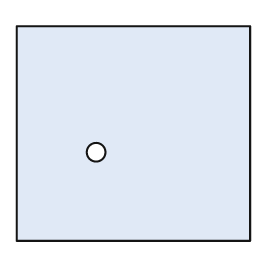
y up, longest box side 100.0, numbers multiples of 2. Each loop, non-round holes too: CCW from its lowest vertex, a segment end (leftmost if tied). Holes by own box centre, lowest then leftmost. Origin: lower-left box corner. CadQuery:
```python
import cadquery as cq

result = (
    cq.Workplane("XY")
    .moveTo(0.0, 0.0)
    .lineTo(100.0, 0.0)
    .lineTo(100.0, 92.0)
    .lineTo(0.0, 92.0)
    .close()
    .moveTo(34.0, 38.0)
    .circle(4.0)
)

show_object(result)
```